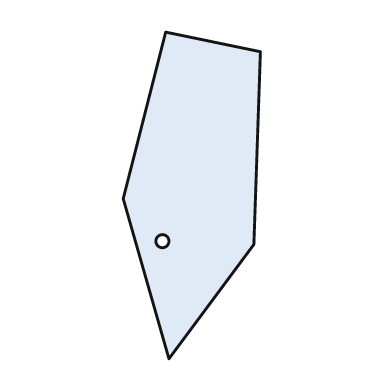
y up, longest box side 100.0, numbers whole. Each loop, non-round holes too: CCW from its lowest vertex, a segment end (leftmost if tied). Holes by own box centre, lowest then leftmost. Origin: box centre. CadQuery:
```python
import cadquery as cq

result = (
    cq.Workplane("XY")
    .moveTo(-7.0, -50.0)
    .lineTo(19.0, -15.0)
    .lineTo(21.0, 44.0)
    .lineTo(-8.0, 50.0)
    .lineTo(-21.0, -1.0)
    .close()
    .moveTo(-9.0, -14.0)
    .circle(2.0)
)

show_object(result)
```